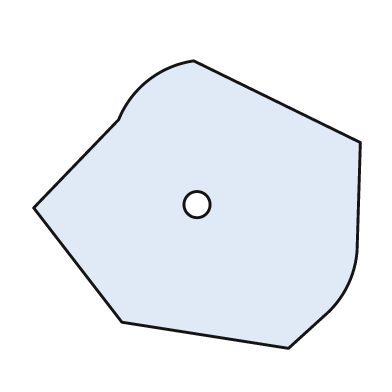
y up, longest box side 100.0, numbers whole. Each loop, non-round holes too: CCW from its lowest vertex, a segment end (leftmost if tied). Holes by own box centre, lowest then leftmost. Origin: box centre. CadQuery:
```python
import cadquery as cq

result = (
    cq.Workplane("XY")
    .moveTo(28.0, -44.0)
    .lineTo(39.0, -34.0)
    .threePointArc((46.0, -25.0), (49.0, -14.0))
    .lineTo(50.0, 19.0)
    .lineTo(-1.0, 44.0)
    .threePointArc((-15.0, 38.0), (-24.0, 26.0))
    .lineTo(-50.0, -1.0)
    .lineTo(-23.0, -36.0)
    .close()
    .moveTo(0.0, 0.0)
    .circle(4.0)
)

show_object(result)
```